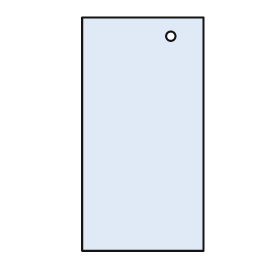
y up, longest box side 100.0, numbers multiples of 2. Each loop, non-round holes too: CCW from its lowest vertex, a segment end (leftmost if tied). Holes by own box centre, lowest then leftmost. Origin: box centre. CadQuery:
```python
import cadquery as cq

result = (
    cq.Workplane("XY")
    .moveTo(-26.0, -50.0)
    .lineTo(26.0, -50.0)
    .lineTo(26.0, 50.0)
    .lineTo(-26.0, 50.0)
    .close()
    .moveTo(12.0, 42.0)
    .circle(2.0)
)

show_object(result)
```